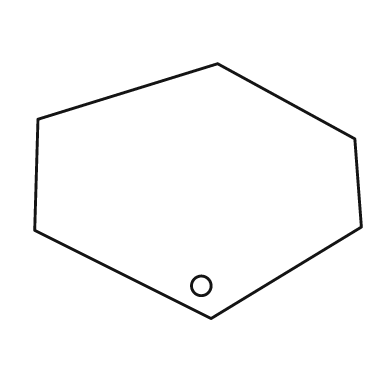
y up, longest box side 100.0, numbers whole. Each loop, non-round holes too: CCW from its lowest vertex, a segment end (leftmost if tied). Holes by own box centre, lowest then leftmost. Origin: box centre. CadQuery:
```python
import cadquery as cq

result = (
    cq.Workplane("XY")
    .moveTo(4.0, -39.0)
    .lineTo(50.0, -11.0)
    .lineTo(48.0, 16.0)
    .lineTo(6.0, 39.0)
    .lineTo(-49.0, 22.0)
    .lineTo(-50.0, -12.0)
    .close()
    .moveTo(1.0, -29.0)
    .circle(3.0)
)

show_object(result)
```